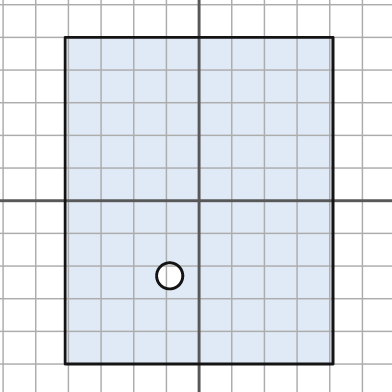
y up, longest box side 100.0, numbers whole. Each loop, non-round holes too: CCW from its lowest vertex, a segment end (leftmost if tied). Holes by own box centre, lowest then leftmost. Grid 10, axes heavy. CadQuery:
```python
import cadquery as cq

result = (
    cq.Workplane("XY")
    .moveTo(-41.0, -50.0)
    .lineTo(41.0, -50.0)
    .lineTo(41.0, 50.0)
    .lineTo(-41.0, 50.0)
    .close()
    .moveTo(-9.0, -23.0)
    .circle(4.0)
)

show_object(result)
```